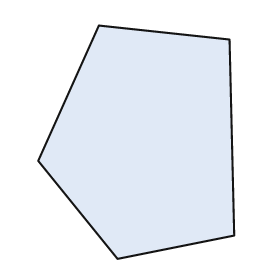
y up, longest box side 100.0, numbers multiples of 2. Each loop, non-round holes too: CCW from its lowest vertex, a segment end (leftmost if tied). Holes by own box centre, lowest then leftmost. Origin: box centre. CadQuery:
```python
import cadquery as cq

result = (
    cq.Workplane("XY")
    .moveTo(-8.0, -50.0)
    .lineTo(42.0, -40.0)
    .lineTo(40.0, 44.0)
    .lineTo(-16.0, 50.0)
    .lineTo(-42.0, -8.0)
    .close()
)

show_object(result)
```